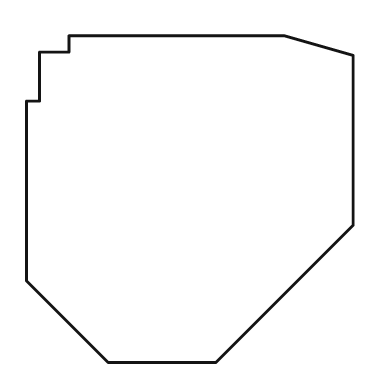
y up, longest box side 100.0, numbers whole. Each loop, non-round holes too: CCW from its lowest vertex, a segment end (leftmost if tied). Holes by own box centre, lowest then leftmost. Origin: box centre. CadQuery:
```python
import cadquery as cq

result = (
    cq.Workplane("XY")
    .moveTo(-25.0, -50.0)
    .lineTo(8.0, -50.0)
    .lineTo(50.0, -8.0)
    .lineTo(50.0, 44.0)
    .lineTo(29.0, 50.0)
    .lineTo(-37.0, 50.0)
    .lineTo(-37.0, 45.0)
    .lineTo(-46.0, 45.0)
    .lineTo(-46.0, 30.0)
    .lineTo(-50.0, 30.0)
    .lineTo(-50.0, -25.0)
    .close()
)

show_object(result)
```